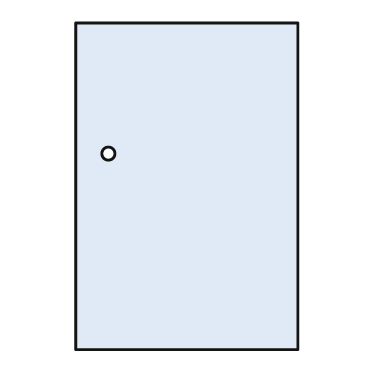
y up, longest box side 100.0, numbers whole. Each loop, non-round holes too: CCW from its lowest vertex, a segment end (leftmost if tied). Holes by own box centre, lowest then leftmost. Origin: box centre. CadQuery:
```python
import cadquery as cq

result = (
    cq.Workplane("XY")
    .moveTo(-34.0, -50.0)
    .lineTo(34.0, -50.0)
    .lineTo(34.0, 50.0)
    .lineTo(-34.0, 50.0)
    .close()
    .moveTo(-24.0, 10.0)
    .circle(2.0)
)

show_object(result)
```